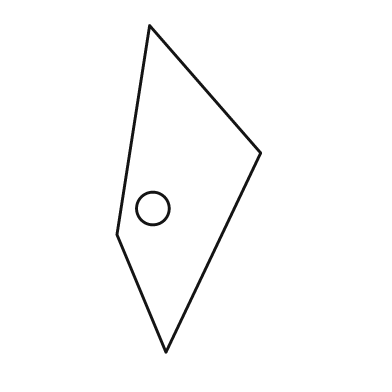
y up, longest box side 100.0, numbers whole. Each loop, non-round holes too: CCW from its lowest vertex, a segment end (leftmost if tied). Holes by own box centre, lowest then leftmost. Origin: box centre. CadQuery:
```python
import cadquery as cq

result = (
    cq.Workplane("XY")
    .moveTo(-7.0, -50.0)
    .lineTo(22.0, 11.0)
    .lineTo(-12.0, 50.0)
    .lineTo(-22.0, -14.0)
    .close()
    .moveTo(-11.0, -6.0)
    .circle(5.0)
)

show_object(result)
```